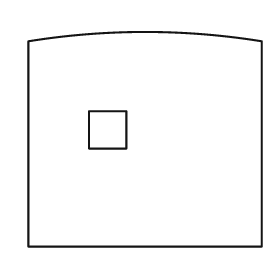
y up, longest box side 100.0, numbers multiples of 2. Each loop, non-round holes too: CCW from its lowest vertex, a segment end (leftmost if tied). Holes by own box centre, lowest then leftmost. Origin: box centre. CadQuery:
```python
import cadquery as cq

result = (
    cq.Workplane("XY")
    .moveTo(-50.0, -46.0)
    .lineTo(50.0, -46.0)
    .lineTo(50.0, 42.0)
    .threePointArc((0.0, 46.0), (-50.0, 42.0))
    .close()
    .moveTo(-24.0, -4.0)
    .lineTo(-8.0, -4.0)
    .lineTo(-8.0, 12.0)
    .lineTo(-24.0, 12.0)
    .close()
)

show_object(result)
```